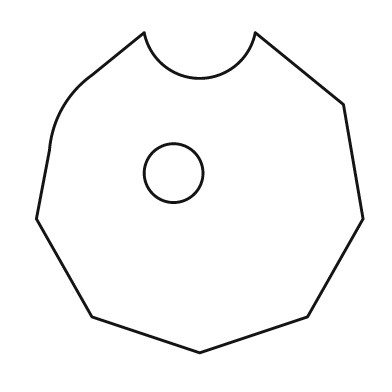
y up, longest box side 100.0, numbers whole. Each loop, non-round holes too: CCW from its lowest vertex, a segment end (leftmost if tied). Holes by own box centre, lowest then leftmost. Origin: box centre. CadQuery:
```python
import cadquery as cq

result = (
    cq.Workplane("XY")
    .moveTo(0.0, -49.0)
    .lineTo(33.0, -38.0)
    .lineTo(50.0, -8.0)
    .lineTo(44.0, 27.0)
    .lineTo(17.0, 49.0)
    .threePointArc((0.0, 35.0), (-17.0, 49.0))
    .lineTo(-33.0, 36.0)
    .threePointArc((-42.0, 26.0), (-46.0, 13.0))
    .lineTo(-50.0, -8.0)
    .lineTo(-33.0, -38.0)
    .close()
    .moveTo(-8.0, 6.0)
    .circle(9.0)
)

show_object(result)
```